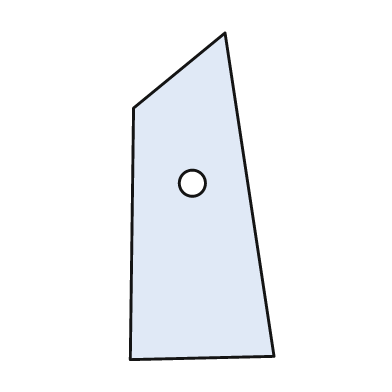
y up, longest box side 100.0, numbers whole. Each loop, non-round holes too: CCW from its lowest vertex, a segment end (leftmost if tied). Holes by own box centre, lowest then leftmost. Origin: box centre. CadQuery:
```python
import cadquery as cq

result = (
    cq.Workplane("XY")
    .moveTo(-22.0, -50.0)
    .lineTo(22.0, -49.0)
    .lineTo(7.0, 50.0)
    .lineTo(-21.0, 27.0)
    .close()
    .moveTo(-3.0, 4.0)
    .circle(4.0)
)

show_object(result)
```